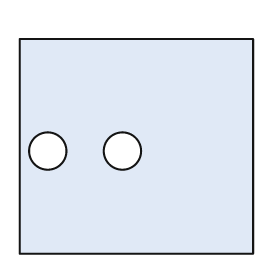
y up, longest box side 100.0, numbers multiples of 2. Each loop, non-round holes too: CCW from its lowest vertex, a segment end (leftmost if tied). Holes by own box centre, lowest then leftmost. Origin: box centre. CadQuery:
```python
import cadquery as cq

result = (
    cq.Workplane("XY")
    .moveTo(-50.0, -46.0)
    .lineTo(50.0, -46.0)
    .lineTo(50.0, 46.0)
    .lineTo(-50.0, 46.0)
    .close()
    .moveTo(-38.0, -2.0)
    .circle(8.0)
    .moveTo(-6.0, -2.0)
    .circle(8.0)
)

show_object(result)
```